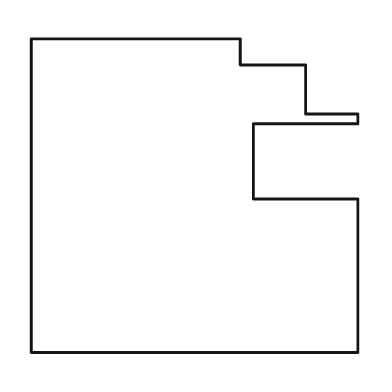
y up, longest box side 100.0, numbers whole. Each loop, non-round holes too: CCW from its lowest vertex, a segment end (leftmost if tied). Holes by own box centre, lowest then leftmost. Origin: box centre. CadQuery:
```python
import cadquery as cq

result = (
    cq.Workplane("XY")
    .moveTo(-50.0, -48.0)
    .lineTo(50.0, -48.0)
    .lineTo(50.0, -1.0)
    .lineTo(18.0, -1.0)
    .lineTo(18.0, 22.0)
    .lineTo(50.0, 22.0)
    .lineTo(50.0, 25.0)
    .lineTo(34.0, 25.0)
    .lineTo(34.0, 40.0)
    .lineTo(14.0, 40.0)
    .lineTo(14.0, 48.0)
    .lineTo(-50.0, 48.0)
    .close()
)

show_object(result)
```